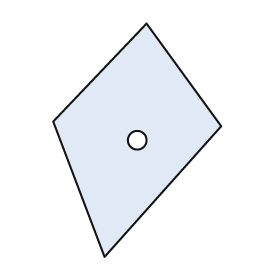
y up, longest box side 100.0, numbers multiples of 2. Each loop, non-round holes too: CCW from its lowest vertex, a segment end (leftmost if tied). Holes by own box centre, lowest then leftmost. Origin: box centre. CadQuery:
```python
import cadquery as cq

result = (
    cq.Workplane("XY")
    .moveTo(-14.0, -50.0)
    .lineTo(36.0, 6.0)
    .lineTo(4.0, 50.0)
    .lineTo(-36.0, 8.0)
    .close()
    .moveTo(0.0, 0.0)
    .circle(4.0)
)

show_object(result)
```